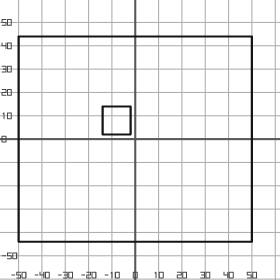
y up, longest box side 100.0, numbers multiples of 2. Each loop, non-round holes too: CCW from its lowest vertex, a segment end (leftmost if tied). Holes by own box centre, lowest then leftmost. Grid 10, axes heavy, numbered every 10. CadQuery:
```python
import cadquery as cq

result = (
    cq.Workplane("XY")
    .moveTo(-50.0, -44.0)
    .lineTo(50.0, -44.0)
    .lineTo(50.0, 44.0)
    .lineTo(-50.0, 44.0)
    .close()
    .moveTo(-14.0, 2.0)
    .lineTo(-2.0, 2.0)
    .lineTo(-2.0, 14.0)
    .lineTo(-14.0, 14.0)
    .close()
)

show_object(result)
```